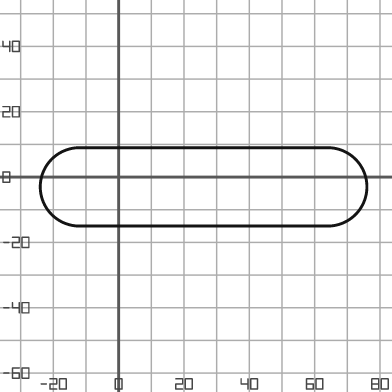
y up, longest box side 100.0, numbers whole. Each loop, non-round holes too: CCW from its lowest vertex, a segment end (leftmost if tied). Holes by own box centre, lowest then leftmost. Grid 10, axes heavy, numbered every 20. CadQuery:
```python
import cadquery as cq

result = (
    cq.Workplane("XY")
    .moveTo(-12.0, -15.0)
    .lineTo(64.0, -15.0)
    .threePointArc((76.0, -3.0), (64.0, 9.0))
    .lineTo(-12.0, 9.0)
    .threePointArc((-24.0, -3.0), (-12.0, -15.0))
    .close()
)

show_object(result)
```